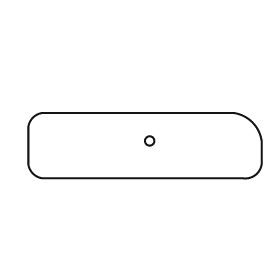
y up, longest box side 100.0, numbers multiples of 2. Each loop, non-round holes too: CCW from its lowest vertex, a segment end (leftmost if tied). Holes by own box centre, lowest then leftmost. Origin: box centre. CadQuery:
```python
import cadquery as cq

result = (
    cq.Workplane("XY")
    .moveTo(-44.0, -14.0)
    .lineTo(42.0, -14.0)
    .threePointArc((48.0, -12.0), (50.0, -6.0))
    .lineTo(50.0, 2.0)
    .threePointArc((46.0, 10.0), (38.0, 14.0))
    .lineTo(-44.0, 14.0)
    .threePointArc((-48.0, 12.0), (-50.0, 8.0))
    .lineTo(-50.0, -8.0)
    .threePointArc((-48.0, -12.0), (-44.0, -14.0))
    .close()
    .moveTo(2.0, 2.0)
    .circle(2.0)
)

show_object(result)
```